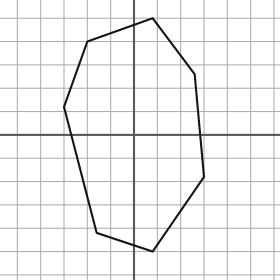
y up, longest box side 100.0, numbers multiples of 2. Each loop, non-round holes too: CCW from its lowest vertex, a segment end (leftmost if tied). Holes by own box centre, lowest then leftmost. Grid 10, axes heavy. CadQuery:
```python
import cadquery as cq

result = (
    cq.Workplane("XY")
    .moveTo(8.0, -50.0)
    .lineTo(30.0, -18.0)
    .lineTo(26.0, 26.0)
    .lineTo(8.0, 50.0)
    .lineTo(-20.0, 40.0)
    .lineTo(-30.0, 12.0)
    .lineTo(-16.0, -42.0)
    .close()
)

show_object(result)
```